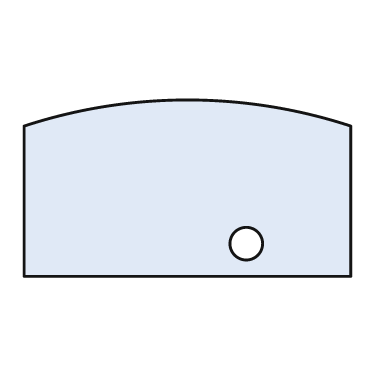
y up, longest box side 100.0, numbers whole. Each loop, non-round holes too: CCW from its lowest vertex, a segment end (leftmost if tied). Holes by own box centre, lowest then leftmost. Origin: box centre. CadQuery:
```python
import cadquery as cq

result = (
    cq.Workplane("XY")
    .moveTo(-50.0, -27.0)
    .lineTo(50.0, -27.0)
    .lineTo(50.0, 19.0)
    .threePointArc((0.0, 27.0), (-50.0, 19.0))
    .close()
    .moveTo(18.0, -17.0)
    .circle(5.0)
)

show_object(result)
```